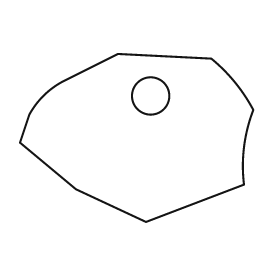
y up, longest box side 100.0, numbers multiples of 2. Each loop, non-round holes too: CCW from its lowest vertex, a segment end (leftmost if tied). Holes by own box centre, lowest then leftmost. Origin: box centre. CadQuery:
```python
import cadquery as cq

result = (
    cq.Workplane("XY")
    .moveTo(4.0, -36.0)
    .lineTo(46.0, -20.0)
    .threePointArc((46.0, -4.0), (50.0, 12.0))
    .threePointArc((42.0, 24.0), (32.0, 34.0))
    .lineTo(-8.0, 36.0)
    .lineTo(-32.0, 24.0)
    .threePointArc((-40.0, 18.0), (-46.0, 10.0))
    .lineTo(-50.0, -2.0)
    .lineTo(-26.0, -22.0)
    .close()
    .moveTo(6.0, 18.0)
    .circle(8.0)
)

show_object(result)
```